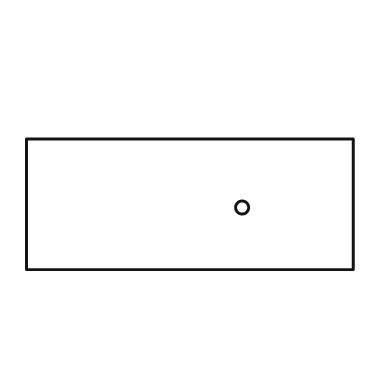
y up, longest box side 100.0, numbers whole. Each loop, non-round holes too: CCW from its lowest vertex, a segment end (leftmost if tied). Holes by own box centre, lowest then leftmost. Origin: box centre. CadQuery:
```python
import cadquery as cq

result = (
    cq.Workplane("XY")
    .moveTo(-50.0, -20.0)
    .lineTo(50.0, -20.0)
    .lineTo(50.0, 20.0)
    .lineTo(-50.0, 20.0)
    .close()
    .moveTo(16.0, -1.0)
    .circle(2.0)
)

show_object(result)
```